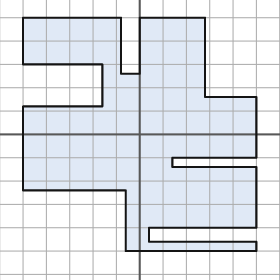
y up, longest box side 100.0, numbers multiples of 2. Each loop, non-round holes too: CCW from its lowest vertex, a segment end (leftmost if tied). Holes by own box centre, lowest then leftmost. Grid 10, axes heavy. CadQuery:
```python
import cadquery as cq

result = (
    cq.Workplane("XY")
    .moveTo(-6.0, -50.0)
    .lineTo(50.0, -50.0)
    .lineTo(50.0, -46.0)
    .lineTo(4.0, -46.0)
    .lineTo(4.0, -40.0)
    .lineTo(50.0, -40.0)
    .lineTo(50.0, -14.0)
    .lineTo(14.0, -14.0)
    .lineTo(14.0, -10.0)
    .lineTo(50.0, -10.0)
    .lineTo(50.0, 16.0)
    .lineTo(28.0, 16.0)
    .lineTo(28.0, 50.0)
    .lineTo(0.0, 50.0)
    .lineTo(0.0, 26.0)
    .lineTo(-8.0, 26.0)
    .lineTo(-8.0, 50.0)
    .lineTo(-50.0, 50.0)
    .lineTo(-50.0, 30.0)
    .lineTo(-16.0, 30.0)
    .lineTo(-16.0, 12.0)
    .lineTo(-50.0, 12.0)
    .lineTo(-50.0, -24.0)
    .lineTo(-6.0, -24.0)
    .close()
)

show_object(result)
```